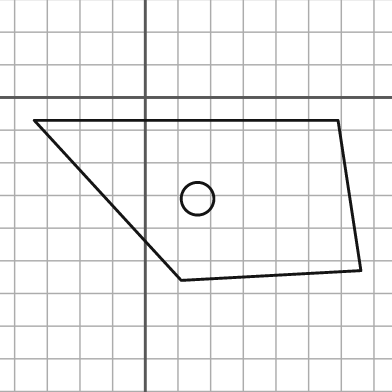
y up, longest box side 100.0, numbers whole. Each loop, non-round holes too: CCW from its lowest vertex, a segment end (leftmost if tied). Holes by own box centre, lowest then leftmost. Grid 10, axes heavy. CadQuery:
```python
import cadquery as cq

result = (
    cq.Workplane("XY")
    .moveTo(11.0, -56.0)
    .lineTo(66.0, -53.0)
    .lineTo(59.0, -7.0)
    .lineTo(-34.0, -7.0)
    .close()
    .moveTo(16.0, -31.0)
    .circle(5.0)
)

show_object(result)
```